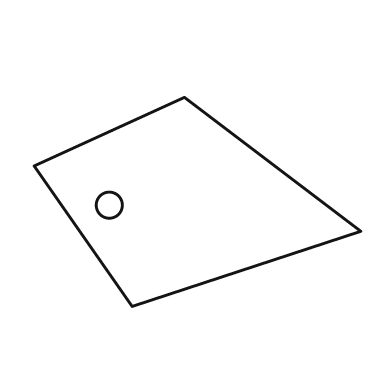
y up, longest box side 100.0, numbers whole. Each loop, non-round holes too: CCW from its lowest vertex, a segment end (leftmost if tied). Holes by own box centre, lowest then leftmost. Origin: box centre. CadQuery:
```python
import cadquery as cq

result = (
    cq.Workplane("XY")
    .moveTo(-20.0, -32.0)
    .lineTo(50.0, -9.0)
    .lineTo(-4.0, 32.0)
    .lineTo(-50.0, 11.0)
    .close()
    .moveTo(-27.0, -1.0)
    .circle(4.0)
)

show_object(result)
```